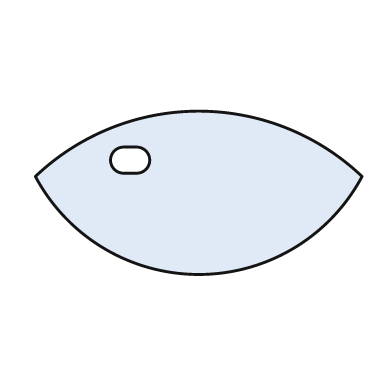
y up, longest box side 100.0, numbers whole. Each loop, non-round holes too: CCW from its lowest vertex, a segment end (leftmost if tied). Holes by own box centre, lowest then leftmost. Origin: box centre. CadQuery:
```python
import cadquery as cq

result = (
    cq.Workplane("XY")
    .moveTo(-50.0, 5.0)
    .threePointArc((0.0, -25.0), (50.0, 5.0))
    .threePointArc((0.0, 25.0), (-50.0, 5.0))
    .close()
    .moveTo(-23.0, 6.0)
    .lineTo(-19.0, 6.0)
    .threePointArc((-15.0, 10.0), (-19.0, 14.0))
    .lineTo(-23.0, 14.0)
    .threePointArc((-27.0, 10.0), (-23.0, 6.0))
    .close()
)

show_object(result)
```